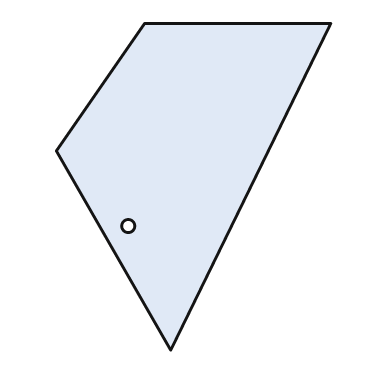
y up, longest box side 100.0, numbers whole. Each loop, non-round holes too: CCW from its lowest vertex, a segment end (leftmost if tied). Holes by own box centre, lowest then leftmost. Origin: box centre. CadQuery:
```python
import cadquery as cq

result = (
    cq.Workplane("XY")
    .moveTo(-7.0, -50.0)
    .lineTo(42.0, 50.0)
    .lineTo(-15.0, 50.0)
    .lineTo(-42.0, 11.0)
    .close()
    .moveTo(-20.0, -12.0)
    .circle(2.0)
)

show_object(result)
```